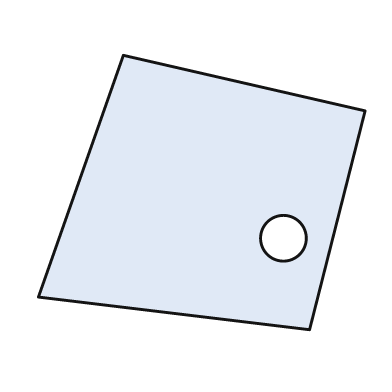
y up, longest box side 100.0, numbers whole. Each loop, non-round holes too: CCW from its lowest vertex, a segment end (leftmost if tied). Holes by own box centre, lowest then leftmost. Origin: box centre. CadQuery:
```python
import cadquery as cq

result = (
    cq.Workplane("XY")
    .moveTo(33.0, -42.0)
    .lineTo(50.0, 25.0)
    .lineTo(-24.0, 42.0)
    .lineTo(-50.0, -32.0)
    .close()
    .moveTo(25.0, -14.0)
    .circle(7.0)
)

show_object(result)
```